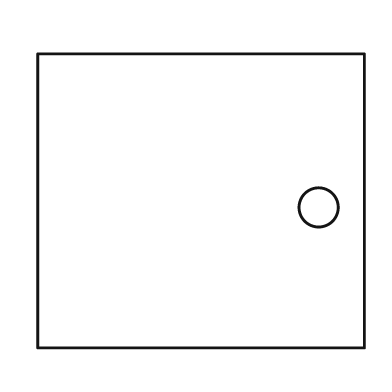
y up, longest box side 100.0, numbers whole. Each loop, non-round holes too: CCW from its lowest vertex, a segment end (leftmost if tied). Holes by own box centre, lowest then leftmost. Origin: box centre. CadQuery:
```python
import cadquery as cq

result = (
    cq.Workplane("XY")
    .moveTo(-50.0, -45.0)
    .lineTo(50.0, -45.0)
    .lineTo(50.0, 45.0)
    .lineTo(-50.0, 45.0)
    .close()
    .moveTo(36.0, -2.0)
    .circle(6.0)
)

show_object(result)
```